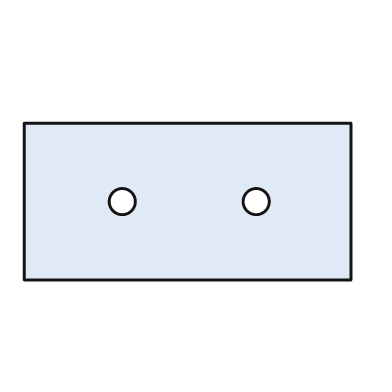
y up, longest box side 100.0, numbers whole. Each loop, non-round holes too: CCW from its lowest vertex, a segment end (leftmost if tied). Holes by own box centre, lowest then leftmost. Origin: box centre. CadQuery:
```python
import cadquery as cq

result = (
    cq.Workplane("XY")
    .moveTo(-50.0, -24.0)
    .lineTo(50.0, -24.0)
    .lineTo(50.0, 24.0)
    .lineTo(-50.0, 24.0)
    .close()
    .moveTo(-20.0, 0.0)
    .circle(4.0)
    .moveTo(21.0, 0.0)
    .circle(4.0)
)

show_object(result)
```